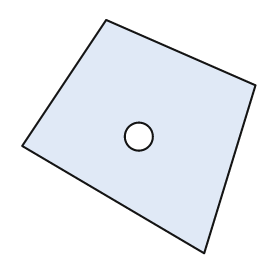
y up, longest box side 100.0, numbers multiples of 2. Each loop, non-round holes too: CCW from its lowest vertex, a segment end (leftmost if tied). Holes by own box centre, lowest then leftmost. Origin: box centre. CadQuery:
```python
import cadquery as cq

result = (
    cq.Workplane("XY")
    .moveTo(28.0, -50.0)
    .lineTo(50.0, 22.0)
    .lineTo(-14.0, 50.0)
    .lineTo(-50.0, -4.0)
    .close()
    .moveTo(0.0, 0.0)
    .circle(6.0)
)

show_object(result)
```